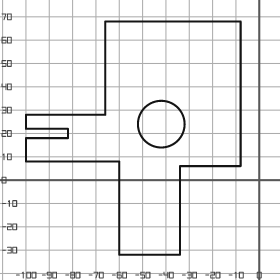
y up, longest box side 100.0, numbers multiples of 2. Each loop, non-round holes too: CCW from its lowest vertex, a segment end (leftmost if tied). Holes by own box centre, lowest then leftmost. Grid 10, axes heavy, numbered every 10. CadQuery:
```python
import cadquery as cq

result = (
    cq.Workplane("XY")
    .moveTo(-60.0, -32.0)
    .lineTo(-34.0, -32.0)
    .lineTo(-34.0, 6.0)
    .lineTo(-8.0, 6.0)
    .lineTo(-8.0, 68.0)
    .lineTo(-66.0, 68.0)
    .lineTo(-66.0, 28.0)
    .lineTo(-100.0, 28.0)
    .lineTo(-100.0, 22.0)
    .lineTo(-82.0, 22.0)
    .lineTo(-82.0, 18.0)
    .lineTo(-100.0, 18.0)
    .lineTo(-100.0, 8.0)
    .lineTo(-60.0, 8.0)
    .close()
    .moveTo(-42.0, 24.0)
    .circle(10.0)
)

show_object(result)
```